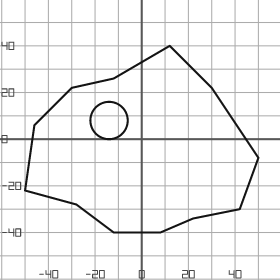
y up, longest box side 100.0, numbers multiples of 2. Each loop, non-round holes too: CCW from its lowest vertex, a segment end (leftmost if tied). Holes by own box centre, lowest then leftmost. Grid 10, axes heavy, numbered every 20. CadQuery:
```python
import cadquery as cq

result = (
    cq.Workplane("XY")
    .moveTo(-12.0, -40.0)
    .lineTo(8.0, -40.0)
    .lineTo(22.0, -34.0)
    .lineTo(42.0, -30.0)
    .lineTo(50.0, -8.0)
    .lineTo(30.0, 22.0)
    .lineTo(12.0, 40.0)
    .lineTo(-12.0, 26.0)
    .lineTo(-30.0, 22.0)
    .lineTo(-46.0, 6.0)
    .lineTo(-50.0, -22.0)
    .lineTo(-28.0, -28.0)
    .close()
    .moveTo(-14.0, 8.0)
    .circle(8.0)
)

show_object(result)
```